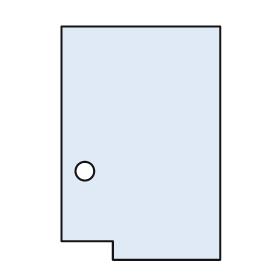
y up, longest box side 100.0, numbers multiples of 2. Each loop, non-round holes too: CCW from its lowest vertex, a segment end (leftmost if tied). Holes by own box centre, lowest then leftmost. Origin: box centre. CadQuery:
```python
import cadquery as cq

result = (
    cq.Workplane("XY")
    .moveTo(-12.0, -50.0)
    .lineTo(34.0, -50.0)
    .lineTo(34.0, 50.0)
    .lineTo(-34.0, 50.0)
    .lineTo(-34.0, -42.0)
    .lineTo(-12.0, -42.0)
    .close()
    .moveTo(-24.0, -12.0)
    .circle(4.0)
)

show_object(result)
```